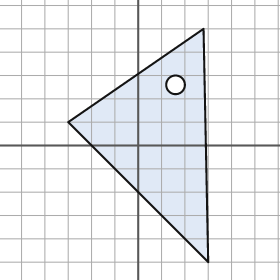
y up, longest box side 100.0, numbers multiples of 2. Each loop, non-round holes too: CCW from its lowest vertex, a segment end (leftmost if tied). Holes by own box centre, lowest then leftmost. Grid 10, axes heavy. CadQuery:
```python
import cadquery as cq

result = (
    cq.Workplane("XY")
    .moveTo(30.0, -50.0)
    .lineTo(28.0, 50.0)
    .lineTo(-30.0, 10.0)
    .close()
    .moveTo(16.0, 26.0)
    .circle(4.0)
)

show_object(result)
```